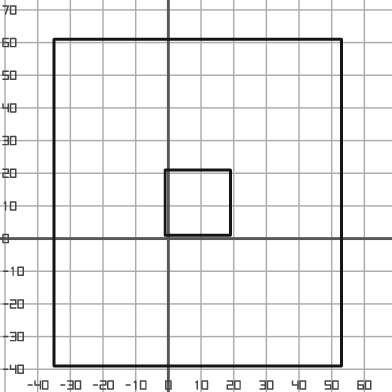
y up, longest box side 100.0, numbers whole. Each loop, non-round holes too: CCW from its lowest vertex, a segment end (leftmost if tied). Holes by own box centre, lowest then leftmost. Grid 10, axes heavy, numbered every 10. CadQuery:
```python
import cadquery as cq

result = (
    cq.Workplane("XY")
    .moveTo(-35.0, -39.0)
    .lineTo(53.0, -39.0)
    .lineTo(53.0, 61.0)
    .lineTo(-35.0, 61.0)
    .close()
    .moveTo(-1.0, 1.0)
    .lineTo(19.0, 1.0)
    .lineTo(19.0, 21.0)
    .lineTo(-1.0, 21.0)
    .close()
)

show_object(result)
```